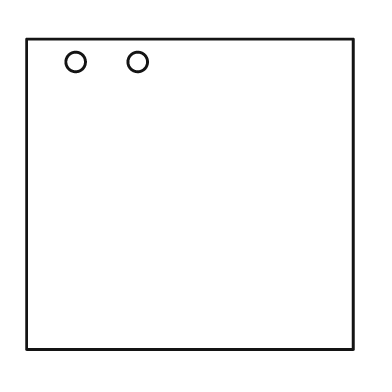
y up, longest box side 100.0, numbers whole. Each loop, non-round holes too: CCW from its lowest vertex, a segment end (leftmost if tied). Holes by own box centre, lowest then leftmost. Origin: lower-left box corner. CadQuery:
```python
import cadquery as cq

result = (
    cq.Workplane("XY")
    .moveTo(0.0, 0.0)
    .lineTo(100.0, 0.0)
    .lineTo(100.0, 95.0)
    .lineTo(0.0, 95.0)
    .close()
    .moveTo(15.0, 88.0)
    .circle(3.0)
    .moveTo(34.0, 88.0)
    .circle(3.0)
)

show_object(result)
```